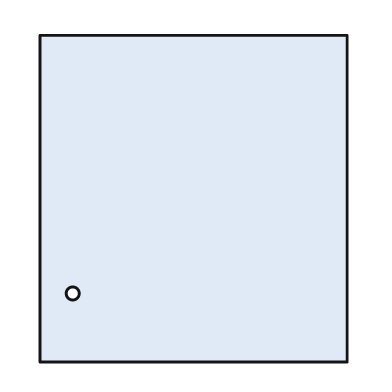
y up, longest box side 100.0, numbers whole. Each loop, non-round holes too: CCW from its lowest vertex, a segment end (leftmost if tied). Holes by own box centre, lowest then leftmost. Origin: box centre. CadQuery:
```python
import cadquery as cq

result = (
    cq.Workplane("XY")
    .moveTo(-47.0, -50.0)
    .lineTo(47.0, -50.0)
    .lineTo(47.0, 50.0)
    .lineTo(-47.0, 50.0)
    .close()
    .moveTo(-37.0, -29.0)
    .circle(2.0)
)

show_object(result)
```